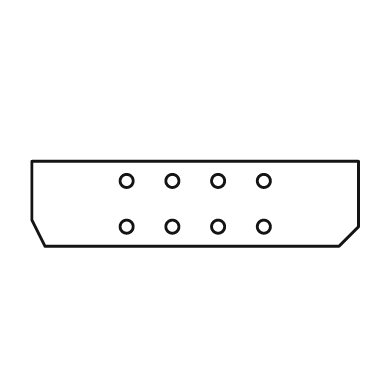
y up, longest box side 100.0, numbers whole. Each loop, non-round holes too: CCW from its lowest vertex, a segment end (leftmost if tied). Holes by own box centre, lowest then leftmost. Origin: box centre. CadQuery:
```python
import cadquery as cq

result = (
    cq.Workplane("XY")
    .moveTo(-46.0, -13.0)
    .lineTo(44.0, -13.0)
    .lineTo(50.0, -7.0)
    .lineTo(50.0, 13.0)
    .lineTo(-50.0, 13.0)
    .lineTo(-50.0, -5.0)
    .close()
    .moveTo(-21.0, -7.0)
    .circle(2.0)
    .moveTo(-7.0, -7.0)
    .circle(2.0)
    .moveTo(7.0, -7.0)
    .circle(2.0)
    .moveTo(21.0, -7.0)
    .circle(2.0)
    .moveTo(-21.0, 7.0)
    .circle(2.0)
    .moveTo(-7.0, 7.0)
    .circle(2.0)
    .moveTo(7.0, 7.0)
    .circle(2.0)
    .moveTo(21.0, 7.0)
    .circle(2.0)
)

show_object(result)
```